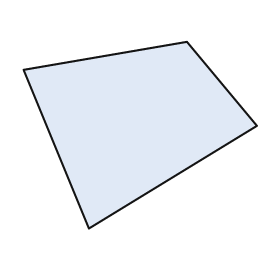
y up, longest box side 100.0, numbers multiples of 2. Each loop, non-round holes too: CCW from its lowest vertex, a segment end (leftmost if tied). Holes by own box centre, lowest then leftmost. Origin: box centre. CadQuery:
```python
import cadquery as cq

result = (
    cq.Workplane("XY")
    .moveTo(-22.0, -40.0)
    .lineTo(50.0, 4.0)
    .lineTo(20.0, 40.0)
    .lineTo(-50.0, 28.0)
    .close()
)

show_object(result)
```